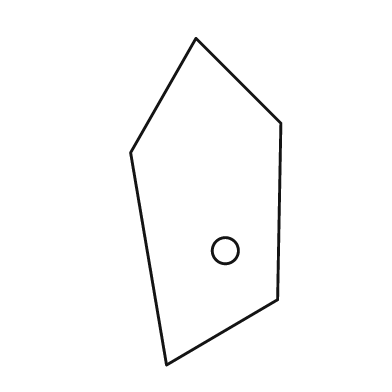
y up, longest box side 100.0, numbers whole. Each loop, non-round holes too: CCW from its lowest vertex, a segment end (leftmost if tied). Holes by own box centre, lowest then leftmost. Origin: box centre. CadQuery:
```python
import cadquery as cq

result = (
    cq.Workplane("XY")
    .moveTo(-12.0, -50.0)
    .lineTo(22.0, -30.0)
    .lineTo(23.0, 24.0)
    .lineTo(-3.0, 50.0)
    .lineTo(-23.0, 15.0)
    .close()
    .moveTo(6.0, -15.0)
    .circle(4.0)
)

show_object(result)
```